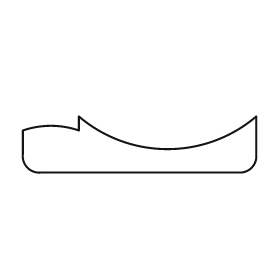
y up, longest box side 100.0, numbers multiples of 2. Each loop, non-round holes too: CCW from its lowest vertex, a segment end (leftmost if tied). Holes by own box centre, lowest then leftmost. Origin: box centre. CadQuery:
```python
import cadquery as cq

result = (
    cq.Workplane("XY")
    .moveTo(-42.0, -12.0)
    .lineTo(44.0, -12.0)
    .threePointArc((48.0, -10.0), (50.0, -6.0))
    .lineTo(50.0, 12.0)
    .threePointArc((12.0, -2.0), (-26.0, 12.0))
    .lineTo(-26.0, 6.0)
    .threePointArc((-38.0, 8.0), (-50.0, 6.0))
    .lineTo(-50.0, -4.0)
    .threePointArc((-48.0, -10.0), (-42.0, -12.0))
    .close()
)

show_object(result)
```